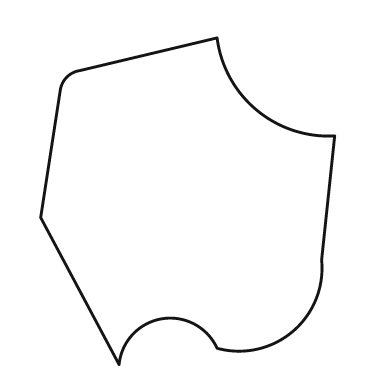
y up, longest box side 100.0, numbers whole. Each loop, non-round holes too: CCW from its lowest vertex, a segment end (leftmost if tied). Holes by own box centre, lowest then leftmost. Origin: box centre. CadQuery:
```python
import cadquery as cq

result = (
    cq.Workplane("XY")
    .moveTo(-21.0, -50.0)
    .threePointArc((-8.0, -36.0), (9.0, -45.0))
    .threePointArc((32.0, -40.0), (41.0, -18.0))
    .lineTo(45.0, 20.0)
    .threePointArc((21.0, 28.0), (9.0, 50.0))
    .lineTo(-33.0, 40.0)
    .threePointArc((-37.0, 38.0), (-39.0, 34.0))
    .lineTo(-45.0, -5.0)
    .close()
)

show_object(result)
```